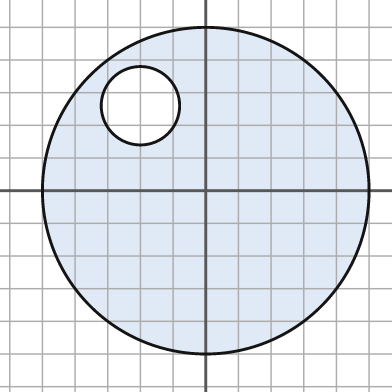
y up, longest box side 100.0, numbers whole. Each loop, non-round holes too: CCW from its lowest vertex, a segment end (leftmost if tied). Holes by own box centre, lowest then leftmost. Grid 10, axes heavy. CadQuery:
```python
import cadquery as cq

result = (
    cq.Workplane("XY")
    .moveTo(0.0, 0.0)
    .circle(50.0)
    .moveTo(-20.0, 26.0)
    .circle(12.0)
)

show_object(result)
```